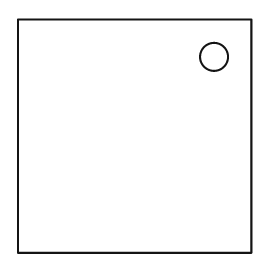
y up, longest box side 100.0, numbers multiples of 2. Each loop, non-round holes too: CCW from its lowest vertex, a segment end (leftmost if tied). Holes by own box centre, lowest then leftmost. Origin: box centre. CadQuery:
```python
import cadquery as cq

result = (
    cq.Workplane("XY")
    .moveTo(-50.0, -50.0)
    .lineTo(50.0, -50.0)
    .lineTo(50.0, 50.0)
    .lineTo(-50.0, 50.0)
    .close()
    .moveTo(34.0, 34.0)
    .circle(6.0)
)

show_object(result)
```